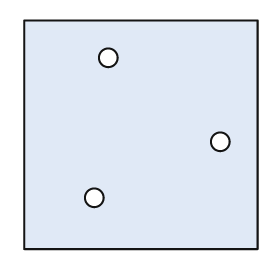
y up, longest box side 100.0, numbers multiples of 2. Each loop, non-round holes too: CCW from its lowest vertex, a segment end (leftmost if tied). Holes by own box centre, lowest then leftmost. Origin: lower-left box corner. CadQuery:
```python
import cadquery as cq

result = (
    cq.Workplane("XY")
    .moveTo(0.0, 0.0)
    .lineTo(100.0, 0.0)
    .lineTo(100.0, 98.0)
    .lineTo(0.0, 98.0)
    .close()
    .moveTo(30.0, 22.0)
    .circle(4.0)
    .moveTo(84.0, 46.0)
    .circle(4.0)
    .moveTo(36.0, 82.0)
    .circle(4.0)
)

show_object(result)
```